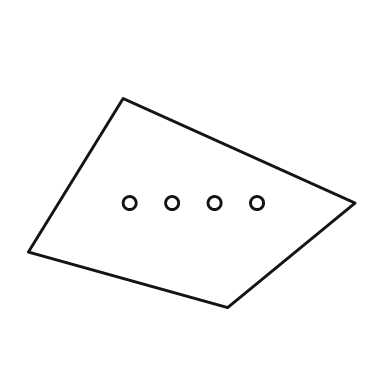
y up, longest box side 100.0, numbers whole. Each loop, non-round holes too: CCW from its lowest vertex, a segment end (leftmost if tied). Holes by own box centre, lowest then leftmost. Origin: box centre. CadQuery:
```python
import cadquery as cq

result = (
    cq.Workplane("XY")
    .moveTo(11.0, -32.0)
    .lineTo(50.0, 0.0)
    .lineTo(-21.0, 32.0)
    .lineTo(-50.0, -15.0)
    .close()
    .moveTo(-19.0, 0.0)
    .circle(2.0)
    .moveTo(-6.0, 0.0)
    .circle(2.0)
    .moveTo(7.0, 0.0)
    .circle(2.0)
    .moveTo(20.0, 0.0)
    .circle(2.0)
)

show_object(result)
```